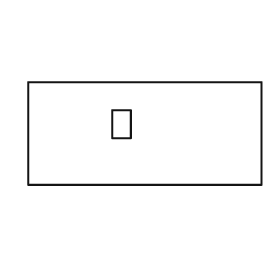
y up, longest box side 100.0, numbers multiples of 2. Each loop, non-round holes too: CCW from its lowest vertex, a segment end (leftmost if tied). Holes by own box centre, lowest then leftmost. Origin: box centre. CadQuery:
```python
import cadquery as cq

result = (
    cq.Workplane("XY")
    .moveTo(-50.0, -22.0)
    .lineTo(50.0, -22.0)
    .lineTo(50.0, 22.0)
    .lineTo(-50.0, 22.0)
    .close()
    .moveTo(-14.0, -2.0)
    .lineTo(-6.0, -2.0)
    .lineTo(-6.0, 10.0)
    .lineTo(-14.0, 10.0)
    .close()
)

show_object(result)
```